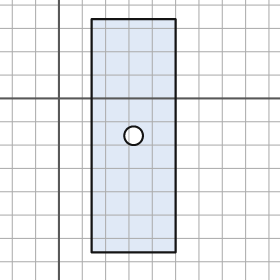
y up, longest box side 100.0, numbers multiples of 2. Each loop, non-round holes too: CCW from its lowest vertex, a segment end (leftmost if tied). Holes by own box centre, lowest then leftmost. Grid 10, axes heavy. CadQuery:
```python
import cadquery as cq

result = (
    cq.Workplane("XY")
    .moveTo(14.0, -66.0)
    .lineTo(50.0, -66.0)
    .lineTo(50.0, 34.0)
    .lineTo(14.0, 34.0)
    .close()
    .moveTo(32.0, -16.0)
    .circle(4.0)
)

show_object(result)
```